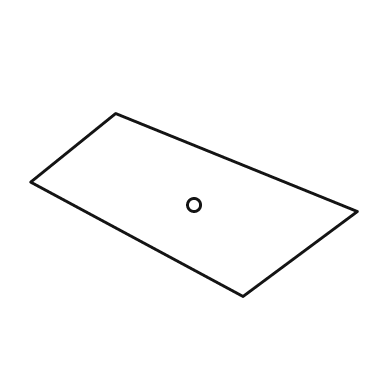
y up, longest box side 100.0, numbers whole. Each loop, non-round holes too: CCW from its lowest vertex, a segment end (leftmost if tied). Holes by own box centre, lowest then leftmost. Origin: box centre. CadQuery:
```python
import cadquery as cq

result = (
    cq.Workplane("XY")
    .moveTo(15.0, -28.0)
    .lineTo(50.0, -2.0)
    .lineTo(-24.0, 28.0)
    .lineTo(-50.0, 7.0)
    .close()
    .moveTo(0.0, 0.0)
    .circle(2.0)
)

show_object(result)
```